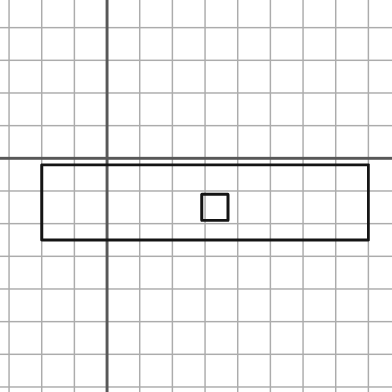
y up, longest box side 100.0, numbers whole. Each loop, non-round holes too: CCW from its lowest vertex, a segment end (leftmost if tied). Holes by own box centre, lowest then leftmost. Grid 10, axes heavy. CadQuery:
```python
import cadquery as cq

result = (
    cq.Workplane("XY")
    .moveTo(-20.0, -25.0)
    .lineTo(80.0, -25.0)
    .lineTo(80.0, -2.0)
    .lineTo(-20.0, -2.0)
    .close()
    .moveTo(29.0, -19.0)
    .lineTo(37.0, -19.0)
    .lineTo(37.0, -11.0)
    .lineTo(29.0, -11.0)
    .close()
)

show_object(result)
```